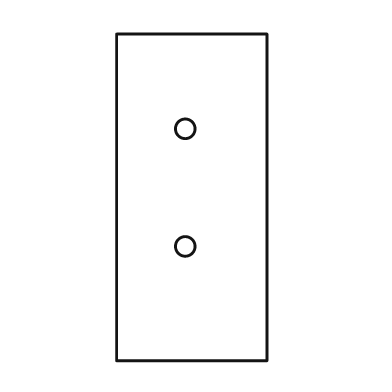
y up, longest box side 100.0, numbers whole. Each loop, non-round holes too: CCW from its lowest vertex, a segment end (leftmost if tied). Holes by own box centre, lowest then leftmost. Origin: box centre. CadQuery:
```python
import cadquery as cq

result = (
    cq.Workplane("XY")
    .moveTo(-23.0, -50.0)
    .lineTo(23.0, -50.0)
    .lineTo(23.0, 50.0)
    .lineTo(-23.0, 50.0)
    .close()
    .moveTo(-2.0, -15.0)
    .circle(3.0)
    .moveTo(-2.0, 21.0)
    .circle(3.0)
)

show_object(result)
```